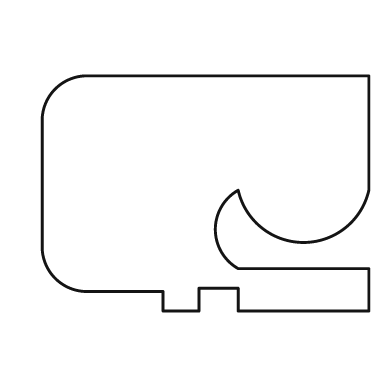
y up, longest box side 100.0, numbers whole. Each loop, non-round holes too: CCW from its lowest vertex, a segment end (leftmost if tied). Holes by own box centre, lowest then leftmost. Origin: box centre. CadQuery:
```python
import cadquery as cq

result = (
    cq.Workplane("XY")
    .moveTo(-13.0, -36.0)
    .lineTo(-2.0, -36.0)
    .lineTo(-2.0, -29.0)
    .lineTo(10.0, -29.0)
    .lineTo(10.0, -36.0)
    .lineTo(50.0, -36.0)
    .lineTo(50.0, -23.0)
    .lineTo(10.0, -23.0)
    .threePointArc((3.0, -11.0), (10.0, 1.0))
    .threePointArc((30.0, -15.0), (50.0, 1.0))
    .lineTo(50.0, 36.0)
    .lineTo(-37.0, 36.0)
    .threePointArc((-46.0, 32.0), (-50.0, 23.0))
    .lineTo(-50.0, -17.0)
    .threePointArc((-46.0, -26.0), (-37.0, -30.0))
    .lineTo(-13.0, -30.0)
    .close()
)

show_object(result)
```